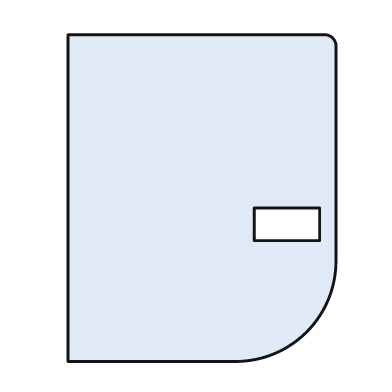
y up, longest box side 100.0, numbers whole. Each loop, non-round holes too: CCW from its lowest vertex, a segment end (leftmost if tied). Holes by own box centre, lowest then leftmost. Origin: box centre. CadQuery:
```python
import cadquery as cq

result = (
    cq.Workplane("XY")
    .moveTo(-41.0, -50.0)
    .lineTo(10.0, -50.0)
    .threePointArc((32.0, -41.0), (41.0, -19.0))
    .lineTo(41.0, 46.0)
    .threePointArc((40.0, 49.0), (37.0, 50.0))
    .lineTo(-41.0, 50.0)
    .close()
    .moveTo(16.0, -13.0)
    .lineTo(36.0, -13.0)
    .lineTo(36.0, -3.0)
    .lineTo(16.0, -3.0)
    .close()
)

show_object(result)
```